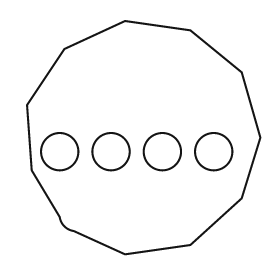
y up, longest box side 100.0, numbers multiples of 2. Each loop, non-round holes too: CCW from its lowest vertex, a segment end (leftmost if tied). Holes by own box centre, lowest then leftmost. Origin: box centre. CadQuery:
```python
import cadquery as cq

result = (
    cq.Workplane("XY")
    .moveTo(-8.0, -50.0)
    .lineTo(20.0, -46.0)
    .lineTo(42.0, -26.0)
    .lineTo(50.0, 0.0)
    .lineTo(42.0, 28.0)
    .lineTo(20.0, 46.0)
    .lineTo(-8.0, 50.0)
    .lineTo(-34.0, 38.0)
    .lineTo(-50.0, 14.0)
    .lineTo(-48.0, -14.0)
    .lineTo(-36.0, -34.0)
    .threePointArc((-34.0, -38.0), (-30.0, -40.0))
    .close()
    .moveTo(-36.0, -6.0)
    .circle(8.0)
    .moveTo(-14.0, -6.0)
    .circle(8.0)
    .moveTo(8.0, -6.0)
    .circle(8.0)
    .moveTo(30.0, -6.0)
    .circle(8.0)
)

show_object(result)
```